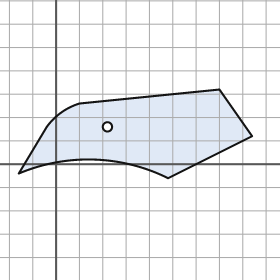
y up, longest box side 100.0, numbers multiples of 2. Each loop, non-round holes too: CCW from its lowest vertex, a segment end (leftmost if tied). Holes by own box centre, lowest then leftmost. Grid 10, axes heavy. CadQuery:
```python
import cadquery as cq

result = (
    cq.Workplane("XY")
    .moveTo(48.0, -6.0)
    .lineTo(84.0, 12.0)
    .lineTo(70.0, 32.0)
    .lineTo(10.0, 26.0)
    .threePointArc((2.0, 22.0), (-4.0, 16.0))
    .lineTo(-16.0, -4.0)
    .threePointArc((16.0, 2.0), (48.0, -6.0))
    .close()
    .moveTo(22.0, 16.0)
    .circle(2.0)
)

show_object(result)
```